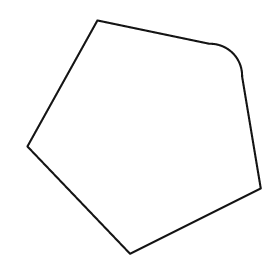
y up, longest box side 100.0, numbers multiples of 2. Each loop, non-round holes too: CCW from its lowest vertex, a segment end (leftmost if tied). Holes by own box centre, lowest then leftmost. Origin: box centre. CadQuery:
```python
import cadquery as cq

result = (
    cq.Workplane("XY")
    .moveTo(-6.0, -50.0)
    .lineTo(50.0, -22.0)
    .lineTo(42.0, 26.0)
    .threePointArc((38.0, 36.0), (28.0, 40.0))
    .lineTo(-20.0, 50.0)
    .lineTo(-50.0, -4.0)
    .close()
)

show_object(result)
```